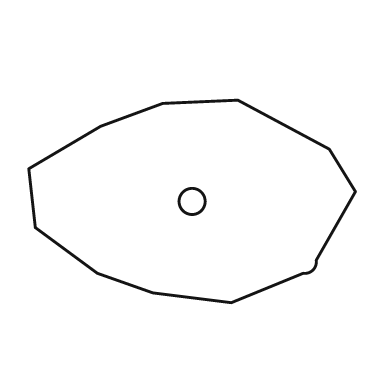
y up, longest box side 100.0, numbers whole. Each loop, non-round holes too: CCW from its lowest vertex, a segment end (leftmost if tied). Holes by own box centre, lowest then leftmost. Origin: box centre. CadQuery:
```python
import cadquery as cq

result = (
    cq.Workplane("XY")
    .moveTo(12.0, -31.0)
    .lineTo(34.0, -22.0)
    .threePointArc((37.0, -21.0), (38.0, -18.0))
    .lineTo(50.0, 3.0)
    .lineTo(42.0, 16.0)
    .lineTo(14.0, 31.0)
    .lineTo(-9.0, 30.0)
    .lineTo(-28.0, 23.0)
    .lineTo(-50.0, 10.0)
    .lineTo(-48.0, -8.0)
    .lineTo(-29.0, -22.0)
    .lineTo(-12.0, -28.0)
    .close()
    .moveTo(0.0, 0.0)
    .circle(4.0)
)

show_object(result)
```